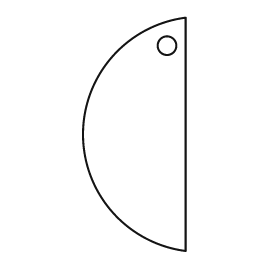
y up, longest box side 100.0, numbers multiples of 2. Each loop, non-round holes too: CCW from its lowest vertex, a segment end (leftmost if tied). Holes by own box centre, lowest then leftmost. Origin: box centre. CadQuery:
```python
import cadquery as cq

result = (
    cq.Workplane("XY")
    .moveTo(22.0, -50.0)
    .lineTo(22.0, 50.0)
    .threePointArc((-22.0, 0.0), (22.0, -50.0))
    .close()
    .moveTo(14.0, 38.0)
    .circle(4.0)
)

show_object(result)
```